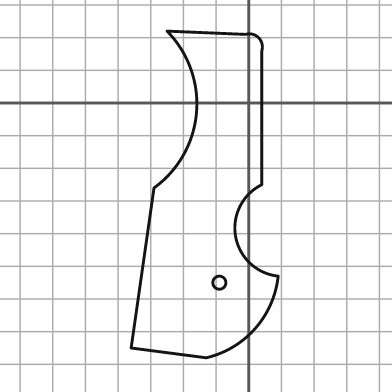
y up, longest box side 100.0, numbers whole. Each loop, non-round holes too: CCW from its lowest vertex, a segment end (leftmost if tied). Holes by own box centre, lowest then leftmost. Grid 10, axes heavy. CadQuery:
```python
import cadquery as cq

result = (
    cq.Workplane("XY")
    .moveTo(-13.0, -78.0)
    .threePointArc((2.0, -69.0), (9.0, -53.0))
    .threePointArc((-4.0, -41.0), (4.0, -25.0))
    .lineTo(4.0, 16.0)
    .threePointArc((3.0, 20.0), (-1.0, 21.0))
    .lineTo(-25.0, 22.0)
    .threePointArc((-16.0, -3.0), (-29.0, -26.0))
    .lineTo(-36.0, -75.0)
    .close()
    .moveTo(-9.0, -55.0)
    .circle(2.0)
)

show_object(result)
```